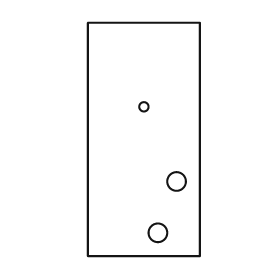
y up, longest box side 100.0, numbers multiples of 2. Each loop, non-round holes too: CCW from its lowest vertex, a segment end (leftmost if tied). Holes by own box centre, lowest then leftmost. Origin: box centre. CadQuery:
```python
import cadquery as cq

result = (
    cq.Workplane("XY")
    .moveTo(-24.0, -50.0)
    .lineTo(24.0, -50.0)
    .lineTo(24.0, 50.0)
    .lineTo(-24.0, 50.0)
    .close()
    .moveTo(6.0, -40.0)
    .circle(4.0)
    .moveTo(14.0, -18.0)
    .circle(4.0)
    .moveTo(0.0, 14.0)
    .circle(2.0)
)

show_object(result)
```